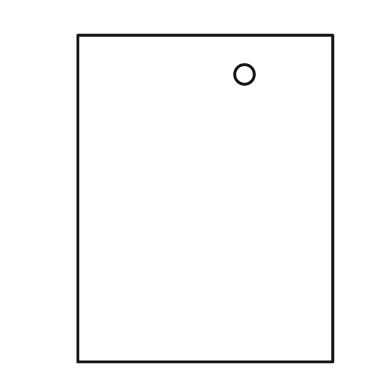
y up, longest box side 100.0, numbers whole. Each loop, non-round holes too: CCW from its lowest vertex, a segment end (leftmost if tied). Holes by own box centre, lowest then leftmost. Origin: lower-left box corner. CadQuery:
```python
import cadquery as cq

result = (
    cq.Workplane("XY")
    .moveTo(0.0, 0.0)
    .lineTo(78.0, 0.0)
    .lineTo(78.0, 100.0)
    .lineTo(0.0, 100.0)
    .close()
    .moveTo(51.0, 88.0)
    .circle(3.0)
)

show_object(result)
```